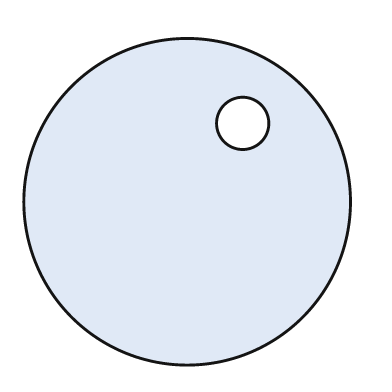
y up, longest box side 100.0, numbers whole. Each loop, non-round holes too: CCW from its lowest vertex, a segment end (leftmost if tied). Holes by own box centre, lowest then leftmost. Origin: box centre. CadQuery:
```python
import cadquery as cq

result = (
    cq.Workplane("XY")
    .moveTo(0.0, 0.0)
    .circle(50.0)
    .moveTo(17.0, 24.0)
    .circle(8.0)
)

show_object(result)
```